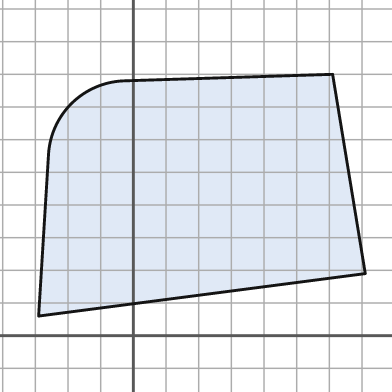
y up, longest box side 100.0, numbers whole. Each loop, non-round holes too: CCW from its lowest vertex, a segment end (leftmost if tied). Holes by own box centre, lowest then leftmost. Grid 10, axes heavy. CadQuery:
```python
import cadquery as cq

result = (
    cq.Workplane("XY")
    .moveTo(-29.0, 6.0)
    .lineTo(71.0, 19.0)
    .lineTo(61.0, 80.0)
    .lineTo(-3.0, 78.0)
    .threePointArc((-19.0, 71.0), (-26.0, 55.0))
    .close()
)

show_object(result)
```